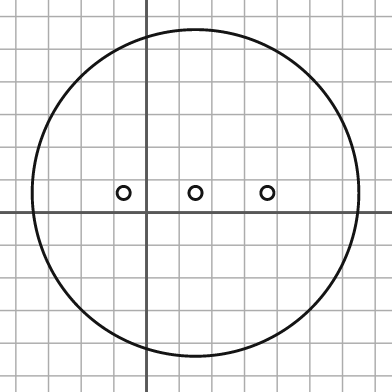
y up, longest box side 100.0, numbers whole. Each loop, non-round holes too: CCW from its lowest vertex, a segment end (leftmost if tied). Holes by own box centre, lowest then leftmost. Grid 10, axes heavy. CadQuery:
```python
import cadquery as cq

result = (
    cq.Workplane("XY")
    .moveTo(15.0, 6.0)
    .circle(50.0)
    .moveTo(-7.0, 6.0)
    .circle(2.0)
    .moveTo(15.0, 6.0)
    .circle(2.0)
    .moveTo(37.0, 6.0)
    .circle(2.0)
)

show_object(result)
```